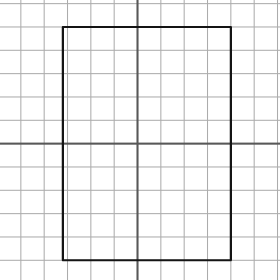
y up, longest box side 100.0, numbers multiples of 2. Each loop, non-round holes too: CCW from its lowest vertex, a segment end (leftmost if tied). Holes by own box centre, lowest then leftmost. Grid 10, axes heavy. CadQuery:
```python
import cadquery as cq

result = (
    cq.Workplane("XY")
    .moveTo(-32.0, -50.0)
    .lineTo(40.0, -50.0)
    .lineTo(40.0, 50.0)
    .lineTo(-32.0, 50.0)
    .close()
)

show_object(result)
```